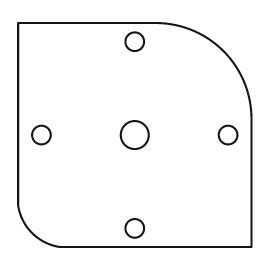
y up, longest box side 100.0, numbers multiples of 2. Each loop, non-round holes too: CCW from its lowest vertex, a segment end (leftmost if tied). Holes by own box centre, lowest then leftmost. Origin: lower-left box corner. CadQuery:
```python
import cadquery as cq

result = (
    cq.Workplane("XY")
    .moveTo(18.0, 0.0)
    .lineTo(100.0, 0.0)
    .lineTo(100.0, 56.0)
    .threePointArc((88.0, 84.0), (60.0, 96.0))
    .lineTo(0.0, 96.0)
    .lineTo(0.0, 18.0)
    .threePointArc((6.0, 6.0), (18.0, 0.0))
    .close()
    .moveTo(50.0, 8.0)
    .circle(4.0)
    .moveTo(10.0, 48.0)
    .circle(4.0)
    .moveTo(50.0, 48.0)
    .circle(6.0)
    .moveTo(90.0, 48.0)
    .circle(4.0)
    .moveTo(50.0, 88.0)
    .circle(4.0)
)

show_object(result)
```